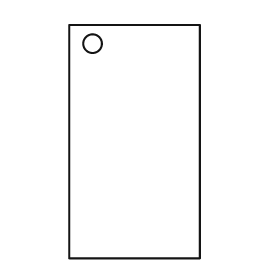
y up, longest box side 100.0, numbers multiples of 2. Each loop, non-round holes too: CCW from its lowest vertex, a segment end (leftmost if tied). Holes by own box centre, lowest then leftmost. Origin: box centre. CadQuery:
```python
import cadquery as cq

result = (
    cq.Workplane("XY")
    .moveTo(-28.0, -50.0)
    .lineTo(28.0, -50.0)
    .lineTo(28.0, 50.0)
    .lineTo(-28.0, 50.0)
    .close()
    .moveTo(-18.0, 42.0)
    .circle(4.0)
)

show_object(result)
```